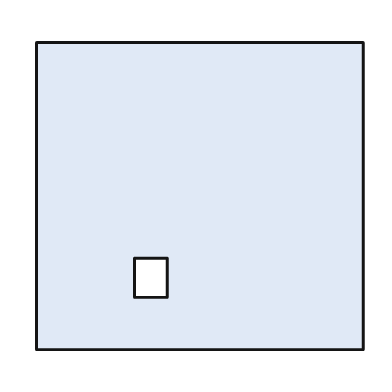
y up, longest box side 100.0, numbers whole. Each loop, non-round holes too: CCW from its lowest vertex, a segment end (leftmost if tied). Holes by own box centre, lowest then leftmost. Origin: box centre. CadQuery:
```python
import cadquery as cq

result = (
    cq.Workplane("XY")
    .moveTo(-50.0, -47.0)
    .lineTo(50.0, -47.0)
    .lineTo(50.0, 47.0)
    .lineTo(-50.0, 47.0)
    .close()
    .moveTo(-20.0, -31.0)
    .lineTo(-10.0, -31.0)
    .lineTo(-10.0, -19.0)
    .lineTo(-20.0, -19.0)
    .close()
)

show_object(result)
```